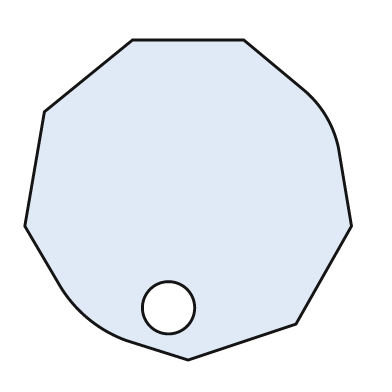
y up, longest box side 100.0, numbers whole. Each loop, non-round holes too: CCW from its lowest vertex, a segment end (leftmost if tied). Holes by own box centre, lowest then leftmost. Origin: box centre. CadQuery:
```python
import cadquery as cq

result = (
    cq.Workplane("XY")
    .moveTo(0.0, -49.0)
    .lineTo(33.0, -38.0)
    .lineTo(50.0, -8.0)
    .lineTo(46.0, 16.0)
    .threePointArc((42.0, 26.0), (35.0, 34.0))
    .lineTo(17.0, 49.0)
    .lineTo(-17.0, 49.0)
    .lineTo(-44.0, 27.0)
    .lineTo(-50.0, -8.0)
    .lineTo(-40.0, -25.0)
    .threePointArc((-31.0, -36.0), (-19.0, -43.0))
    .close()
    .moveTo(-6.0, -33.0)
    .circle(8.0)
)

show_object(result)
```